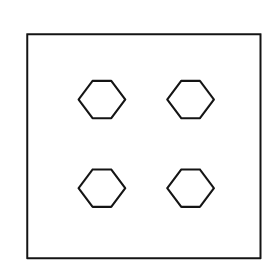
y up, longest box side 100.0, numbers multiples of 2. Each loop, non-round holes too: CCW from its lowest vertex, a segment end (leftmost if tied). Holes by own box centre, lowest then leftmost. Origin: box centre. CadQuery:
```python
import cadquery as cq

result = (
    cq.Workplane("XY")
    .moveTo(-50.0, -48.0)
    .lineTo(50.0, -48.0)
    .lineTo(50.0, 48.0)
    .lineTo(-50.0, 48.0)
    .close()
    .moveTo(-22.0, -26.0)
    .lineTo(-14.0, -26.0)
    .lineTo(-8.0, -18.0)
    .lineTo(-14.0, -10.0)
    .lineTo(-22.0, -10.0)
    .lineTo(-28.0, -18.0)
    .close()
    .moveTo(16.0, -26.0)
    .lineTo(24.0, -26.0)
    .lineTo(30.0, -18.0)
    .lineTo(24.0, -10.0)
    .lineTo(16.0, -10.0)
    .lineTo(10.0, -18.0)
    .close()
    .moveTo(-22.0, 12.0)
    .lineTo(-14.0, 12.0)
    .lineTo(-8.0, 20.0)
    .lineTo(-14.0, 28.0)
    .lineTo(-22.0, 28.0)
    .lineTo(-28.0, 20.0)
    .close()
    .moveTo(16.0, 12.0)
    .lineTo(24.0, 12.0)
    .lineTo(30.0, 20.0)
    .lineTo(24.0, 28.0)
    .lineTo(16.0, 28.0)
    .lineTo(10.0, 20.0)
    .close()
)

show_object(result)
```